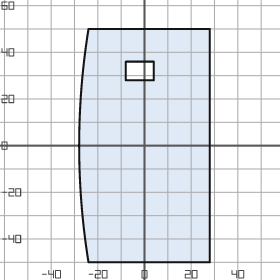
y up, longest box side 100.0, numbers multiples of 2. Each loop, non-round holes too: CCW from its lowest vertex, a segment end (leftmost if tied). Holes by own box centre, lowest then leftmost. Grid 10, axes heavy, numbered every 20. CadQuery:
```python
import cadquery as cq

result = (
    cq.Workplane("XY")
    .moveTo(-24.0, -50.0)
    .lineTo(28.0, -50.0)
    .lineTo(28.0, 50.0)
    .lineTo(-24.0, 50.0)
    .threePointArc((-28.0, 0.0), (-24.0, -50.0))
    .close()
    .moveTo(-8.0, 28.0)
    .lineTo(4.0, 28.0)
    .lineTo(4.0, 36.0)
    .lineTo(-8.0, 36.0)
    .close()
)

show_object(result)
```